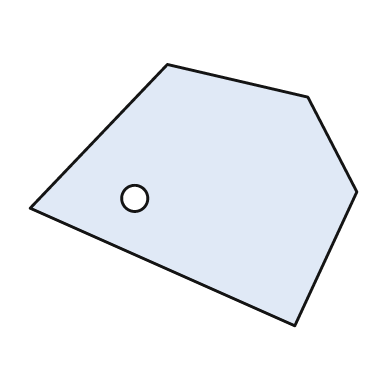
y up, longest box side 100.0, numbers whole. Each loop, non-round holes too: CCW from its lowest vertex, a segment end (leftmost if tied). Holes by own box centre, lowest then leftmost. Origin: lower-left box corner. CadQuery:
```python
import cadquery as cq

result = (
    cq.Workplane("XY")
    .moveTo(81.0, 0.0)
    .lineTo(100.0, 41.0)
    .lineTo(85.0, 70.0)
    .lineTo(42.0, 80.0)
    .lineTo(0.0, 36.0)
    .close()
    .moveTo(32.0, 39.0)
    .circle(4.0)
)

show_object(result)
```